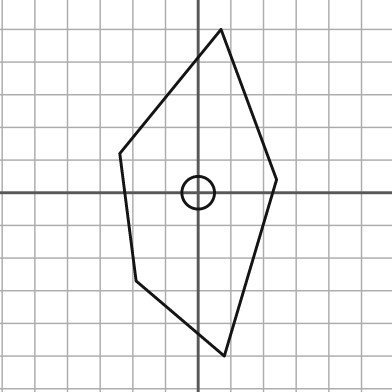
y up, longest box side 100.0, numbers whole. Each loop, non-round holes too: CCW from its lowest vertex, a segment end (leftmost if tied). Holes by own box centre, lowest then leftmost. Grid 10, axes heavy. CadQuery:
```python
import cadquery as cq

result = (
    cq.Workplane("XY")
    .moveTo(8.0, -50.0)
    .lineTo(24.0, 4.0)
    .lineTo(7.0, 50.0)
    .lineTo(-24.0, 12.0)
    .lineTo(-19.0, -27.0)
    .close()
    .moveTo(0.0, 0.0)
    .circle(5.0)
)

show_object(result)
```